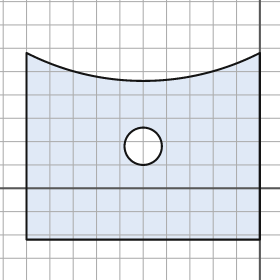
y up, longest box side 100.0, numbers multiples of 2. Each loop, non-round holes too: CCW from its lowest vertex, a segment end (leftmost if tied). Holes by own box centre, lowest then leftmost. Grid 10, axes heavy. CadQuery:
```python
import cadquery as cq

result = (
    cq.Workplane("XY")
    .moveTo(-100.0, -22.0)
    .lineTo(0.0, -22.0)
    .lineTo(0.0, 58.0)
    .threePointArc((-50.0, 46.0), (-100.0, 58.0))
    .close()
    .moveTo(-50.0, 18.0)
    .circle(8.0)
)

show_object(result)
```